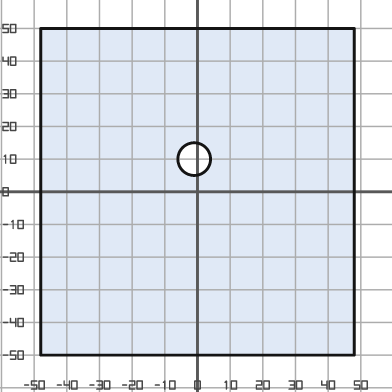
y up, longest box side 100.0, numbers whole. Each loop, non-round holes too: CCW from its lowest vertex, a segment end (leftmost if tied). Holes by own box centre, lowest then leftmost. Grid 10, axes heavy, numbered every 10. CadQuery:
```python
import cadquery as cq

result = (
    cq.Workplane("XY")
    .moveTo(-48.0, -50.0)
    .lineTo(48.0, -50.0)
    .lineTo(48.0, 50.0)
    .lineTo(-48.0, 50.0)
    .close()
    .moveTo(-1.0, 10.0)
    .circle(5.0)
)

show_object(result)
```